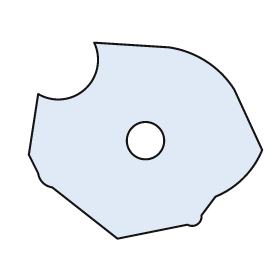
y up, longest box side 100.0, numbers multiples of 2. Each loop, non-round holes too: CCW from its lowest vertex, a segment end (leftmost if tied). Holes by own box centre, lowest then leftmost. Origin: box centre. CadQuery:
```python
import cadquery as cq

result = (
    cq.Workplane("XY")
    .moveTo(-12.0, -42.0)
    .lineTo(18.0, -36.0)
    .threePointArc((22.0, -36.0), (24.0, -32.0))
    .lineTo(30.0, -24.0)
    .threePointArc((42.0, -16.0), (50.0, -4.0))
    .lineTo(38.0, 22.0)
    .threePointArc((26.0, 34.0), (10.0, 40.0))
    .lineTo(-22.0, 42.0)
    .threePointArc((-26.0, 22.0), (-46.0, 20.0))
    .lineTo(-50.0, -6.0)
    .lineTo(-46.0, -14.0)
    .threePointArc((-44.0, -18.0), (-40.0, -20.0))
    .close()
    .moveTo(0.0, 0.0)
    .circle(8.0)
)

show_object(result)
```